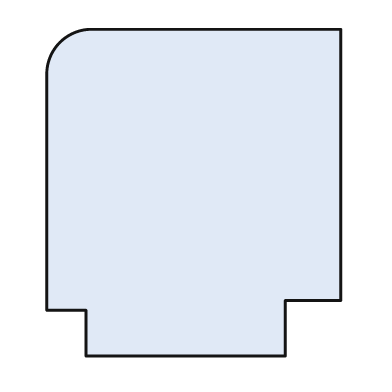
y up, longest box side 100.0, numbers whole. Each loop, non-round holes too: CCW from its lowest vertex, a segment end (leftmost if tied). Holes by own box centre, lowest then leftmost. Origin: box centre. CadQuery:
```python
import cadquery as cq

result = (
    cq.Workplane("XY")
    .moveTo(-33.0, -50.0)
    .lineTo(28.0, -50.0)
    .lineTo(28.0, -33.0)
    .lineTo(45.0, -33.0)
    .lineTo(45.0, 50.0)
    .lineTo(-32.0, 50.0)
    .threePointArc((-41.0, 46.0), (-45.0, 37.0))
    .lineTo(-45.0, -36.0)
    .lineTo(-33.0, -36.0)
    .close()
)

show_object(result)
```